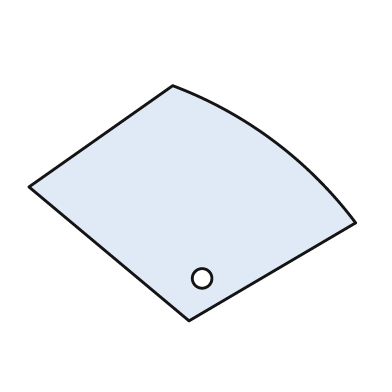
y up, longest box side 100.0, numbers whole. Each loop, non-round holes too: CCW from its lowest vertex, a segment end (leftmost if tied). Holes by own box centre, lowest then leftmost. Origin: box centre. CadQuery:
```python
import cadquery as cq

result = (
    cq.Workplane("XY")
    .moveTo(-1.0, -36.0)
    .lineTo(50.0, -6.0)
    .threePointArc((25.0, 19.0), (-6.0, 36.0))
    .lineTo(-50.0, 5.0)
    .close()
    .moveTo(3.0, -23.0)
    .circle(3.0)
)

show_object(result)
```